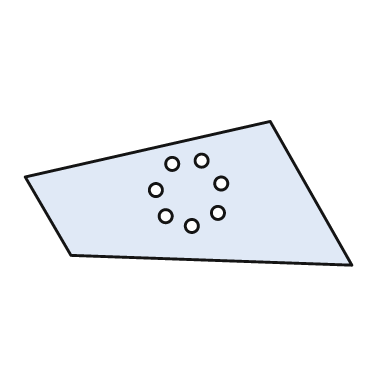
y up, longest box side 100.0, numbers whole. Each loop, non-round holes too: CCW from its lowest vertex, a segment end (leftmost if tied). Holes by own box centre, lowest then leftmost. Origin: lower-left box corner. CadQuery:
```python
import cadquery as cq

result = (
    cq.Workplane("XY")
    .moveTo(100.0, 0.0)
    .lineTo(75.0, 44.0)
    .lineTo(0.0, 27.0)
    .lineTo(14.0, 3.0)
    .close()
    .moveTo(51.0, 12.0)
    .circle(2.0)
    .moveTo(43.0, 15.0)
    .circle(2.0)
    .moveTo(59.0, 16.0)
    .circle(2.0)
    .moveTo(40.0, 23.0)
    .circle(2.0)
    .moveTo(60.0, 25.0)
    .circle(2.0)
    .moveTo(45.0, 31.0)
    .circle(2.0)
    .moveTo(54.0, 32.0)
    .circle(2.0)
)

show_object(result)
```